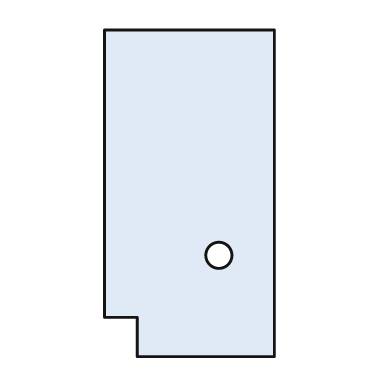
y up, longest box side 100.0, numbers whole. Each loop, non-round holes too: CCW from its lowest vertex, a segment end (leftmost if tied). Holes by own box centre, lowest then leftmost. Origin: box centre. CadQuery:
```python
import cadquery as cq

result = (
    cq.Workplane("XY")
    .moveTo(-16.0, -50.0)
    .lineTo(26.0, -50.0)
    .lineTo(26.0, 50.0)
    .lineTo(-26.0, 50.0)
    .lineTo(-26.0, -38.0)
    .lineTo(-16.0, -38.0)
    .close()
    .moveTo(9.0, -19.0)
    .circle(4.0)
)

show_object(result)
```